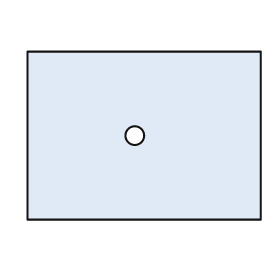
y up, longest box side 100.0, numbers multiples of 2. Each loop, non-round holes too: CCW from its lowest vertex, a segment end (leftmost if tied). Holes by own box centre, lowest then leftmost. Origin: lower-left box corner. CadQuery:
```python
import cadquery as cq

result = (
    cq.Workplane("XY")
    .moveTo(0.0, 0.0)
    .lineTo(100.0, 0.0)
    .lineTo(100.0, 72.0)
    .lineTo(0.0, 72.0)
    .close()
    .moveTo(46.0, 36.0)
    .circle(4.0)
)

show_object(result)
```